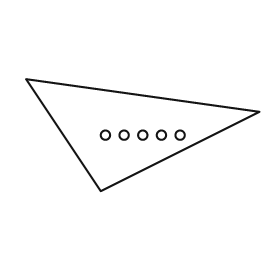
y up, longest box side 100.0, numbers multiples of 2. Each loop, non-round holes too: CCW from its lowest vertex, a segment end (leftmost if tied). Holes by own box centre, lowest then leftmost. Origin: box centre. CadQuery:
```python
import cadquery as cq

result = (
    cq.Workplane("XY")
    .moveTo(-18.0, -24.0)
    .lineTo(50.0, 10.0)
    .lineTo(-50.0, 24.0)
    .close()
    .moveTo(-16.0, 0.0)
    .circle(2.0)
    .moveTo(-8.0, 0.0)
    .circle(2.0)
    .moveTo(0.0, 0.0)
    .circle(2.0)
    .moveTo(8.0, 0.0)
    .circle(2.0)
    .moveTo(16.0, 0.0)
    .circle(2.0)
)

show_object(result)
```